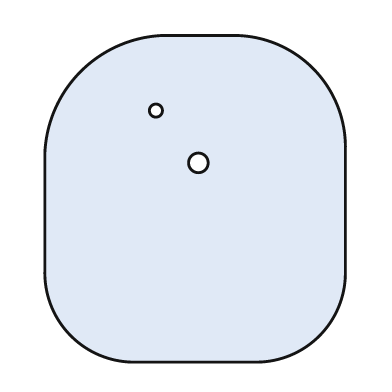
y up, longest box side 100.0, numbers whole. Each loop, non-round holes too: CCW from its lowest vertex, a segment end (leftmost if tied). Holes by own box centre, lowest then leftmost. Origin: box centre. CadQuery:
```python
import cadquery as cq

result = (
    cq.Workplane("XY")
    .moveTo(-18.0, -50.0)
    .lineTo(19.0, -50.0)
    .threePointArc((38.0, -42.0), (46.0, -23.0))
    .lineTo(46.0, 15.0)
    .threePointArc((36.0, 40.0), (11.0, 50.0))
    .lineTo(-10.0, 50.0)
    .threePointArc((-35.0, 39.0), (-46.0, 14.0))
    .lineTo(-46.0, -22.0)
    .threePointArc((-38.0, -42.0), (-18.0, -50.0))
    .close()
    .moveTo(1.0, 11.0)
    .circle(3.0)
    .moveTo(-12.0, 27.0)
    .circle(2.0)
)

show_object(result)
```